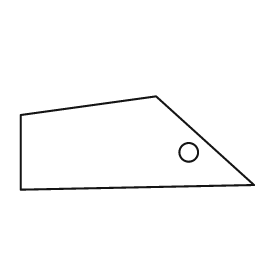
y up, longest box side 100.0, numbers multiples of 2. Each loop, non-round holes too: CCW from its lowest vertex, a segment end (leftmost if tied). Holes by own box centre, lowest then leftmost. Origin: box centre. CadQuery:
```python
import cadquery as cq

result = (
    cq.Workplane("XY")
    .moveTo(-50.0, -20.0)
    .lineTo(50.0, -18.0)
    .lineTo(8.0, 20.0)
    .lineTo(-50.0, 12.0)
    .close()
    .moveTo(22.0, -4.0)
    .circle(4.0)
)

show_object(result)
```